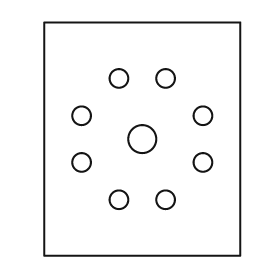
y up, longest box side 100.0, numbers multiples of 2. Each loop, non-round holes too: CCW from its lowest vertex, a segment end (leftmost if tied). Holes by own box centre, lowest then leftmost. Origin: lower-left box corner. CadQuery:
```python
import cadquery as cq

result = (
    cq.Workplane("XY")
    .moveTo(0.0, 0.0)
    .lineTo(84.0, 0.0)
    .lineTo(84.0, 100.0)
    .lineTo(0.0, 100.0)
    .close()
    .moveTo(32.0, 24.0)
    .circle(4.0)
    .moveTo(52.0, 24.0)
    .circle(4.0)
    .moveTo(16.0, 40.0)
    .circle(4.0)
    .moveTo(68.0, 40.0)
    .circle(4.0)
    .moveTo(42.0, 50.0)
    .circle(6.0)
    .moveTo(16.0, 60.0)
    .circle(4.0)
    .moveTo(68.0, 60.0)
    .circle(4.0)
    .moveTo(32.0, 76.0)
    .circle(4.0)
    .moveTo(52.0, 76.0)
    .circle(4.0)
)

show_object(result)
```